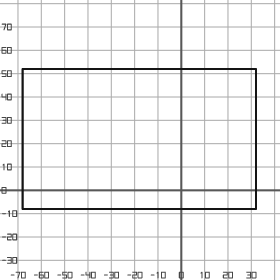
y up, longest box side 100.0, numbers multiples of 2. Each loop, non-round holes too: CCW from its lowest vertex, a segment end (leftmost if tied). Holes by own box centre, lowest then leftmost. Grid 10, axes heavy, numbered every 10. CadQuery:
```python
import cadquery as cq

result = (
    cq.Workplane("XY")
    .moveTo(-68.0, -8.0)
    .lineTo(32.0, -8.0)
    .lineTo(32.0, 52.0)
    .lineTo(-68.0, 52.0)
    .close()
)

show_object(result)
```